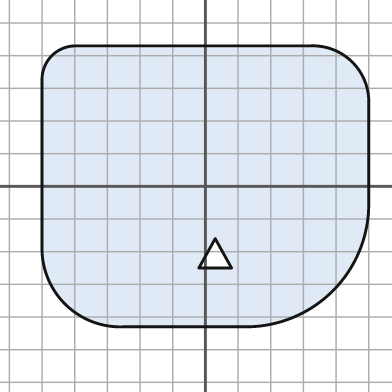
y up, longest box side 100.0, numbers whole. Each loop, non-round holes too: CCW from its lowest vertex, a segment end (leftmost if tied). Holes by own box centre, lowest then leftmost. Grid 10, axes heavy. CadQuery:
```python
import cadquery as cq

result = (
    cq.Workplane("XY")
    .moveTo(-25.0, -43.0)
    .lineTo(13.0, -43.0)
    .threePointArc((39.0, -32.0), (50.0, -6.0))
    .lineTo(50.0, 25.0)
    .threePointArc((45.0, 38.0), (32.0, 43.0))
    .lineTo(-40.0, 43.0)
    .threePointArc((-47.0, 40.0), (-50.0, 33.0))
    .lineTo(-50.0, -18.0)
    .threePointArc((-43.0, -36.0), (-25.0, -43.0))
    .close()
    .moveTo(-2.0, -25.0)
    .lineTo(8.0, -25.0)
    .lineTo(3.0, -16.0)
    .close()
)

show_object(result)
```